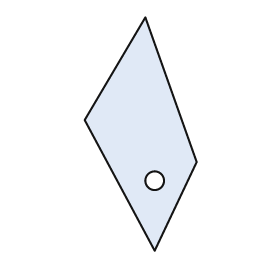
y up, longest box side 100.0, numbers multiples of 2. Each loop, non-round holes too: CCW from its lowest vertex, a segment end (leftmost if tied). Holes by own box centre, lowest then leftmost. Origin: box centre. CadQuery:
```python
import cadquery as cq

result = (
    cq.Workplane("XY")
    .moveTo(6.0, -50.0)
    .lineTo(24.0, -12.0)
    .lineTo(2.0, 50.0)
    .lineTo(-24.0, 6.0)
    .close()
    .moveTo(6.0, -20.0)
    .circle(4.0)
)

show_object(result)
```